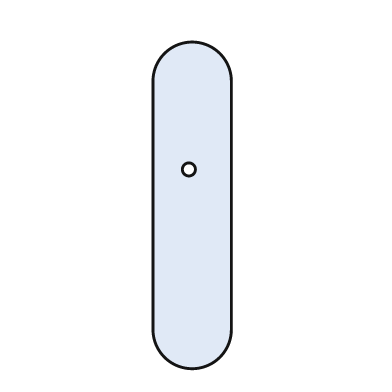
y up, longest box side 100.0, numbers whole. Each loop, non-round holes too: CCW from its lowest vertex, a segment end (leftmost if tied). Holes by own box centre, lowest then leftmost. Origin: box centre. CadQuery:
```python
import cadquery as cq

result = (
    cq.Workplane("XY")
    .moveTo(-12.0, -38.0)
    .threePointArc((0.0, -50.0), (12.0, -38.0))
    .lineTo(12.0, 38.0)
    .threePointArc((0.0, 50.0), (-12.0, 38.0))
    .close()
    .moveTo(-1.0, 11.0)
    .circle(2.0)
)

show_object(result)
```